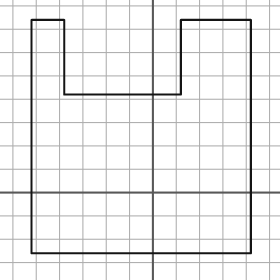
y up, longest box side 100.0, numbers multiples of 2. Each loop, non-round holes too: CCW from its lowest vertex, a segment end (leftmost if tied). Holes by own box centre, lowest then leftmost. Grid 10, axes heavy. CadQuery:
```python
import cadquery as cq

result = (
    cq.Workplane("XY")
    .moveTo(-52.0, -26.0)
    .lineTo(42.0, -26.0)
    .lineTo(42.0, 74.0)
    .lineTo(12.0, 74.0)
    .lineTo(12.0, 42.0)
    .lineTo(-38.0, 42.0)
    .lineTo(-38.0, 74.0)
    .lineTo(-52.0, 74.0)
    .close()
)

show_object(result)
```